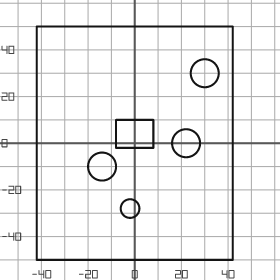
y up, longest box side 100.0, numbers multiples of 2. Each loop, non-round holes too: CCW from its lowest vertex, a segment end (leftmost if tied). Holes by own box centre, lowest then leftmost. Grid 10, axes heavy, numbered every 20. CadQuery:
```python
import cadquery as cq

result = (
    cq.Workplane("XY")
    .moveTo(-42.0, -50.0)
    .lineTo(42.0, -50.0)
    .lineTo(42.0, 50.0)
    .lineTo(-42.0, 50.0)
    .close()
    .moveTo(-2.0, -28.0)
    .circle(4.0)
    .moveTo(-14.0, -10.0)
    .circle(6.0)
    .moveTo(22.0, 0.0)
    .circle(6.0)
    .moveTo(-8.0, -2.0)
    .lineTo(8.0, -2.0)
    .lineTo(8.0, 10.0)
    .lineTo(-8.0, 10.0)
    .close()
    .moveTo(30.0, 30.0)
    .circle(6.0)
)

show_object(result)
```